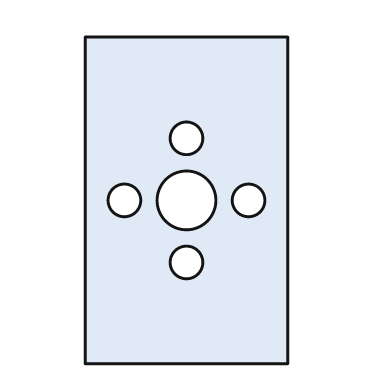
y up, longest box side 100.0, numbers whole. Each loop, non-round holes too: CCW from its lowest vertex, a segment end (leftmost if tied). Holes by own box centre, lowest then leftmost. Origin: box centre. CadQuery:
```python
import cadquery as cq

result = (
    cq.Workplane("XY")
    .moveTo(-31.0, -50.0)
    .lineTo(31.0, -50.0)
    .lineTo(31.0, 50.0)
    .lineTo(-31.0, 50.0)
    .close()
    .moveTo(0.0, -19.0)
    .circle(5.0)
    .moveTo(-19.0, 0.0)
    .circle(5.0)
    .moveTo(0.0, 0.0)
    .circle(9.0)
    .moveTo(19.0, 0.0)
    .circle(5.0)
    .moveTo(0.0, 19.0)
    .circle(5.0)
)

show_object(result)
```